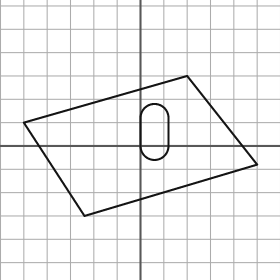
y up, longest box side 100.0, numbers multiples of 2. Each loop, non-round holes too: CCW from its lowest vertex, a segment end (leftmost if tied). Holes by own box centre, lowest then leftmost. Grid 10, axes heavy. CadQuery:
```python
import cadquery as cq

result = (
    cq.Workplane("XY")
    .moveTo(-24.0, -30.0)
    .lineTo(50.0, -8.0)
    .lineTo(20.0, 30.0)
    .lineTo(-50.0, 10.0)
    .close()
    .moveTo(0.0, 0.0)
    .threePointArc((6.0, -6.0), (12.0, 0.0))
    .lineTo(12.0, 12.0)
    .threePointArc((6.0, 18.0), (0.0, 12.0))
    .close()
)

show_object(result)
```